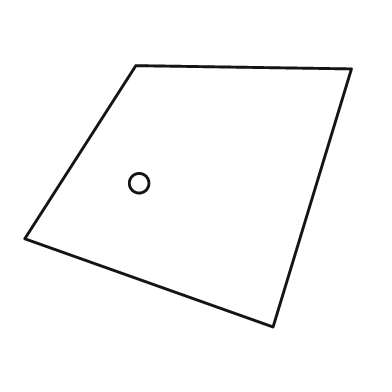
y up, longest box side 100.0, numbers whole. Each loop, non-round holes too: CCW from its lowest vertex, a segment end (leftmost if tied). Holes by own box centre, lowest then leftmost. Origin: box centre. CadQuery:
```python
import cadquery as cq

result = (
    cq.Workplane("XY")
    .moveTo(26.0, -40.0)
    .lineTo(50.0, 39.0)
    .lineTo(-16.0, 40.0)
    .lineTo(-50.0, -13.0)
    .close()
    .moveTo(-15.0, 4.0)
    .circle(3.0)
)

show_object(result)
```